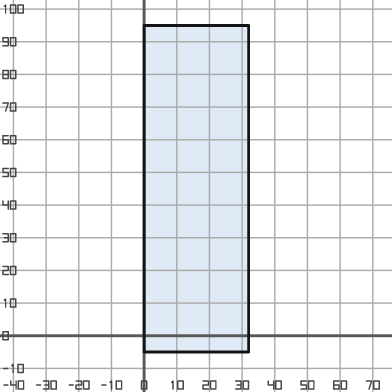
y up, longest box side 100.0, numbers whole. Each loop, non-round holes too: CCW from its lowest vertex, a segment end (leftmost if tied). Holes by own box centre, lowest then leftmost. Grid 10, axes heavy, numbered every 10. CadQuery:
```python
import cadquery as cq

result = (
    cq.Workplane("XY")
    .moveTo(0.0, -5.0)
    .lineTo(32.0, -5.0)
    .lineTo(32.0, 95.0)
    .lineTo(0.0, 95.0)
    .close()
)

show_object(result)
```